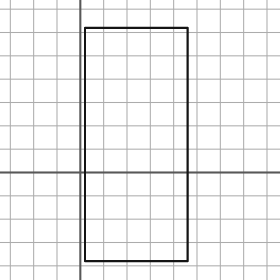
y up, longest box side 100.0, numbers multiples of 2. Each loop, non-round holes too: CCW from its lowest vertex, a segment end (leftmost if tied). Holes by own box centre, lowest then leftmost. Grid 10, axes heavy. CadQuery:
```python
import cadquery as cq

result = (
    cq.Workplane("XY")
    .moveTo(2.0, -38.0)
    .lineTo(46.0, -38.0)
    .lineTo(46.0, 62.0)
    .lineTo(2.0, 62.0)
    .close()
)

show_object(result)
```